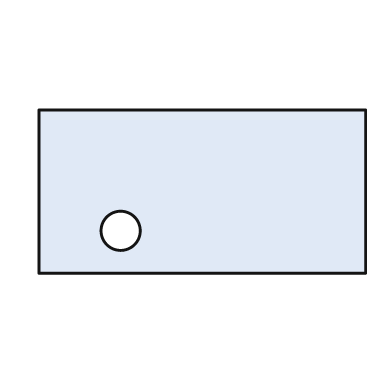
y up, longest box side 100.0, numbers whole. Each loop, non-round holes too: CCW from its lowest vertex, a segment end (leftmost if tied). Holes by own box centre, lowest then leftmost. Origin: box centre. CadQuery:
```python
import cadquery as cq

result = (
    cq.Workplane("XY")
    .moveTo(-50.0, -25.0)
    .lineTo(50.0, -25.0)
    .lineTo(50.0, 25.0)
    .lineTo(-50.0, 25.0)
    .close()
    .moveTo(-25.0, -12.0)
    .circle(6.0)
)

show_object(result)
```